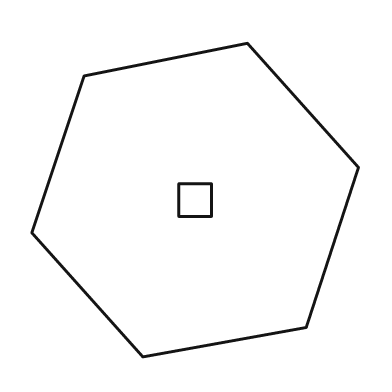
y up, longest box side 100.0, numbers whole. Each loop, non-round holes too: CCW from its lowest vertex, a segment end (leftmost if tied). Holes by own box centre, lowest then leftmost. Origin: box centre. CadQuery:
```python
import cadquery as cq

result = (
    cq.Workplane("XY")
    .moveTo(-16.0, -48.0)
    .lineTo(34.0, -39.0)
    .lineTo(50.0, 10.0)
    .lineTo(16.0, 48.0)
    .lineTo(-34.0, 38.0)
    .lineTo(-50.0, -10.0)
    .close()
    .moveTo(-5.0, -5.0)
    .lineTo(5.0, -5.0)
    .lineTo(5.0, 5.0)
    .lineTo(-5.0, 5.0)
    .close()
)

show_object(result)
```